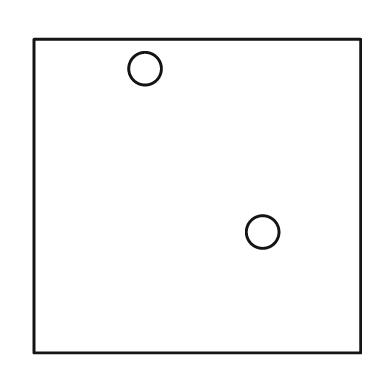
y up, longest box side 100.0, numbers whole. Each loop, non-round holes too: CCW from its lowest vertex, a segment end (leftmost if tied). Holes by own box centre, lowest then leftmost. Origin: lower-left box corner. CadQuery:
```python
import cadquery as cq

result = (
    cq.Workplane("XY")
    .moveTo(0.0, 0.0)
    .lineTo(100.0, 0.0)
    .lineTo(100.0, 96.0)
    .lineTo(0.0, 96.0)
    .close()
    .moveTo(70.0, 37.0)
    .circle(5.0)
    .moveTo(34.0, 87.0)
    .circle(5.0)
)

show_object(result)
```